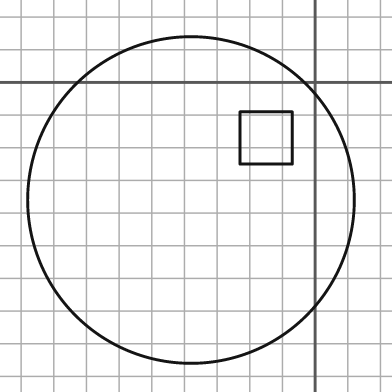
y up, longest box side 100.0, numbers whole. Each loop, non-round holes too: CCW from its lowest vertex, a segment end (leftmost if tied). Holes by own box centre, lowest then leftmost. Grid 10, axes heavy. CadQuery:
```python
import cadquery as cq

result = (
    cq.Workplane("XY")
    .moveTo(-38.0, -36.0)
    .circle(50.0)
    .moveTo(-23.0, -25.0)
    .lineTo(-7.0, -25.0)
    .lineTo(-7.0, -9.0)
    .lineTo(-23.0, -9.0)
    .close()
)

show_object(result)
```